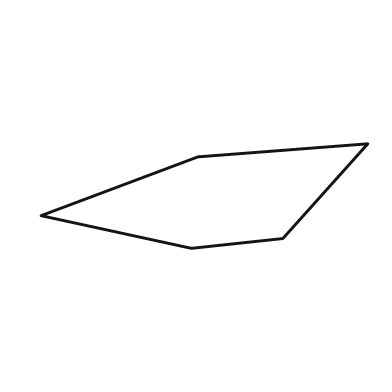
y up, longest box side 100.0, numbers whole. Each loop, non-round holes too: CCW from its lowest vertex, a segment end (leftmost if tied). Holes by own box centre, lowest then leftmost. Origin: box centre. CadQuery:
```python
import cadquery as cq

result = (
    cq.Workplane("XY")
    .moveTo(-4.0, -16.0)
    .lineTo(24.0, -13.0)
    .lineTo(50.0, 16.0)
    .lineTo(-2.0, 12.0)
    .lineTo(-50.0, -6.0)
    .close()
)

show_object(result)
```